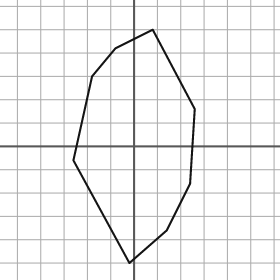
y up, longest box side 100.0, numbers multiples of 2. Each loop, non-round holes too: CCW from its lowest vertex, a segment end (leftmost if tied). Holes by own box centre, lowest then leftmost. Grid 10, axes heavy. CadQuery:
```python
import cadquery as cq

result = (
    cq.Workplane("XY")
    .moveTo(-2.0, -50.0)
    .lineTo(14.0, -36.0)
    .lineTo(24.0, -16.0)
    .lineTo(26.0, 16.0)
    .lineTo(8.0, 50.0)
    .lineTo(-8.0, 42.0)
    .lineTo(-18.0, 30.0)
    .lineTo(-26.0, -6.0)
    .close()
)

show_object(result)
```